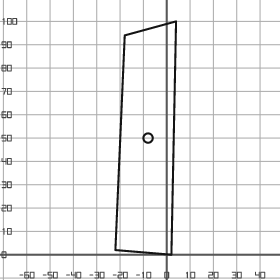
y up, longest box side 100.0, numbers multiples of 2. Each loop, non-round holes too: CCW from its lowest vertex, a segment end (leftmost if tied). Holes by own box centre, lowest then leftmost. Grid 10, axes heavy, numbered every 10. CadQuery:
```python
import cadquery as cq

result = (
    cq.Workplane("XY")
    .moveTo(2.0, 0.0)
    .lineTo(4.0, 100.0)
    .lineTo(-18.0, 94.0)
    .lineTo(-22.0, 2.0)
    .close()
    .moveTo(-8.0, 50.0)
    .circle(2.0)
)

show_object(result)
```